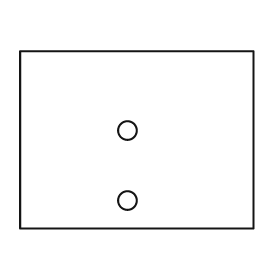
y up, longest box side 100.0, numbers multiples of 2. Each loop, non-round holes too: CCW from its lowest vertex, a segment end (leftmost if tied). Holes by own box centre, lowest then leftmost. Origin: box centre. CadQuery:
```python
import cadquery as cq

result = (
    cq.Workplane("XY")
    .moveTo(-50.0, -38.0)
    .lineTo(50.0, -38.0)
    .lineTo(50.0, 38.0)
    .lineTo(-50.0, 38.0)
    .close()
    .moveTo(-4.0, -26.0)
    .circle(4.0)
    .moveTo(-4.0, 4.0)
    .circle(4.0)
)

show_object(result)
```